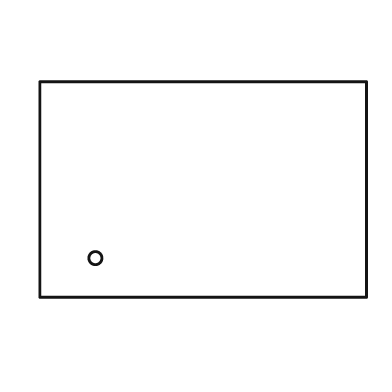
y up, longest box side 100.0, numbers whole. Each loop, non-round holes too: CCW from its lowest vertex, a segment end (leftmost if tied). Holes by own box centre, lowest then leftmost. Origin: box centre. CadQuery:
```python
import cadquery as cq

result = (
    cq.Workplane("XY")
    .moveTo(-50.0, -33.0)
    .lineTo(50.0, -33.0)
    .lineTo(50.0, 33.0)
    .lineTo(-50.0, 33.0)
    .close()
    .moveTo(-33.0, -21.0)
    .circle(2.0)
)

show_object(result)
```